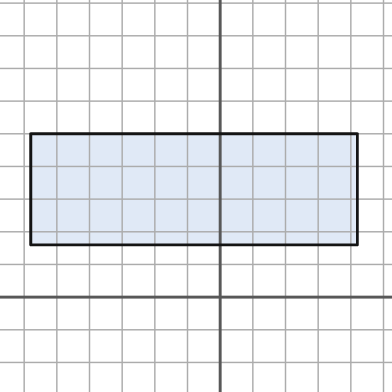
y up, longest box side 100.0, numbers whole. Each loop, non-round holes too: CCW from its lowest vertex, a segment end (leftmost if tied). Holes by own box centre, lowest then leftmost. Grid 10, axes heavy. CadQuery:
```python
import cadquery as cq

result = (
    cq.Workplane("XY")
    .moveTo(-58.0, 16.0)
    .lineTo(42.0, 16.0)
    .lineTo(42.0, 50.0)
    .lineTo(-58.0, 50.0)
    .close()
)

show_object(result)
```